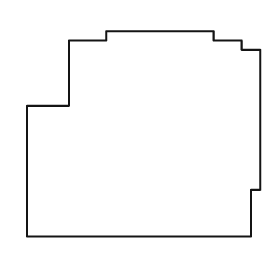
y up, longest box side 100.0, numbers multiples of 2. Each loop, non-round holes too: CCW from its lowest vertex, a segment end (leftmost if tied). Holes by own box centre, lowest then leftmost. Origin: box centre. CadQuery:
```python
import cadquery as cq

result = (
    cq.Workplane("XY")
    .moveTo(-50.0, -44.0)
    .lineTo(46.0, -44.0)
    .lineTo(46.0, -24.0)
    .lineTo(50.0, -24.0)
    .lineTo(50.0, 36.0)
    .lineTo(42.0, 36.0)
    .lineTo(42.0, 40.0)
    .lineTo(30.0, 40.0)
    .lineTo(30.0, 44.0)
    .lineTo(-16.0, 44.0)
    .lineTo(-16.0, 40.0)
    .lineTo(-32.0, 40.0)
    .lineTo(-32.0, 12.0)
    .lineTo(-50.0, 12.0)
    .close()
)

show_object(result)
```